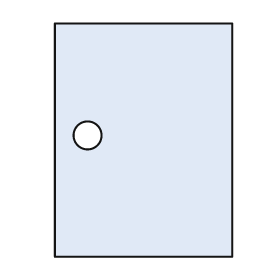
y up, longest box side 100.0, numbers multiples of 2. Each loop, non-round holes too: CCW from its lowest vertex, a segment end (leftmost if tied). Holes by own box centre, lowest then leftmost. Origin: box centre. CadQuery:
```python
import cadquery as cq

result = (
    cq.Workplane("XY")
    .moveTo(-38.0, -50.0)
    .lineTo(38.0, -50.0)
    .lineTo(38.0, 50.0)
    .lineTo(-38.0, 50.0)
    .close()
    .moveTo(-24.0, 2.0)
    .circle(6.0)
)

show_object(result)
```